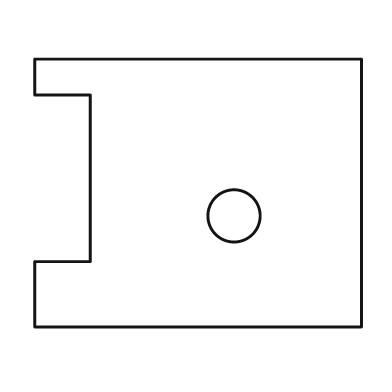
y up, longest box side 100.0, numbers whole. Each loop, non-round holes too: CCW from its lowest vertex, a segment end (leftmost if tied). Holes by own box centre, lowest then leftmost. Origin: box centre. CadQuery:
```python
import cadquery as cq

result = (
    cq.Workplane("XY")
    .moveTo(-50.0, -41.0)
    .lineTo(50.0, -41.0)
    .lineTo(50.0, 41.0)
    .lineTo(-50.0, 41.0)
    .lineTo(-50.0, 30.0)
    .lineTo(-33.0, 30.0)
    .lineTo(-33.0, -21.0)
    .lineTo(-50.0, -21.0)
    .close()
    .moveTo(11.0, -7.0)
    .circle(8.0)
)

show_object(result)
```